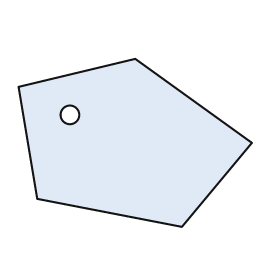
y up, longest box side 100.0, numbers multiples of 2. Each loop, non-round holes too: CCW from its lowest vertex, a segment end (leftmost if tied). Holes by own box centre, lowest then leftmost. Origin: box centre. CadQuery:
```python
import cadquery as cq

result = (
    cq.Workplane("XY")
    .moveTo(20.0, -36.0)
    .lineTo(50.0, 0.0)
    .lineTo(0.0, 36.0)
    .lineTo(-50.0, 24.0)
    .lineTo(-42.0, -24.0)
    .close()
    .moveTo(-28.0, 12.0)
    .circle(4.0)
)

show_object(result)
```